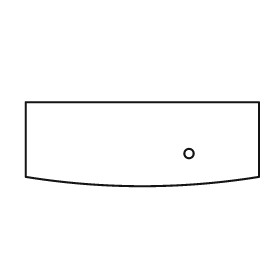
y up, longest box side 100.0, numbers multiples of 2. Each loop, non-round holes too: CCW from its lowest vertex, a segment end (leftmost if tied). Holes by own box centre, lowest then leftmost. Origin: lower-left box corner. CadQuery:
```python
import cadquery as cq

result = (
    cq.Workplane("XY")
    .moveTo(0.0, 4.0)
    .threePointArc((50.0, 0.0), (100.0, 4.0))
    .lineTo(100.0, 36.0)
    .lineTo(0.0, 36.0)
    .close()
    .moveTo(70.0, 14.0)
    .circle(2.0)
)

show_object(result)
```